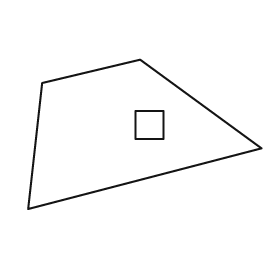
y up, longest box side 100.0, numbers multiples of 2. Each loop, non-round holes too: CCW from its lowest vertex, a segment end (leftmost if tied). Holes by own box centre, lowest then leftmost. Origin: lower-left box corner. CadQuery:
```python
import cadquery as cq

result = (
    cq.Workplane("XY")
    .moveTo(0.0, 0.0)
    .lineTo(100.0, 26.0)
    .lineTo(48.0, 64.0)
    .lineTo(6.0, 54.0)
    .close()
    .moveTo(46.0, 30.0)
    .lineTo(58.0, 30.0)
    .lineTo(58.0, 42.0)
    .lineTo(46.0, 42.0)
    .close()
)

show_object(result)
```